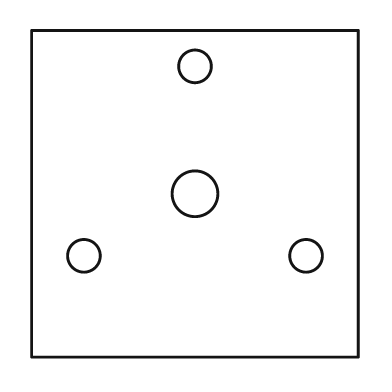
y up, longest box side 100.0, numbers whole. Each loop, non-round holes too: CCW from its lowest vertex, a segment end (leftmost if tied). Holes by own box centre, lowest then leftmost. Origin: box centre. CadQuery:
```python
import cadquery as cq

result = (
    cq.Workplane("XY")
    .moveTo(-50.0, -50.0)
    .lineTo(50.0, -50.0)
    .lineTo(50.0, 50.0)
    .lineTo(-50.0, 50.0)
    .close()
    .moveTo(-34.0, -19.0)
    .circle(5.0)
    .moveTo(34.0, -19.0)
    .circle(5.0)
    .moveTo(0.0, 0.0)
    .circle(7.0)
    .moveTo(0.0, 39.0)
    .circle(5.0)
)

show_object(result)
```